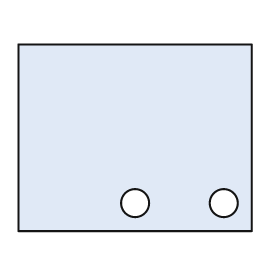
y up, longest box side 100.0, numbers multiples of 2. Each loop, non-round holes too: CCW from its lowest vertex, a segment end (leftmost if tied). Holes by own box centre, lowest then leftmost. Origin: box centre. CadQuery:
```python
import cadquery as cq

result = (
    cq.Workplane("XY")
    .moveTo(-50.0, -40.0)
    .lineTo(50.0, -40.0)
    .lineTo(50.0, 40.0)
    .lineTo(-50.0, 40.0)
    .close()
    .moveTo(0.0, -28.0)
    .circle(6.0)
    .moveTo(38.0, -28.0)
    .circle(6.0)
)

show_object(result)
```